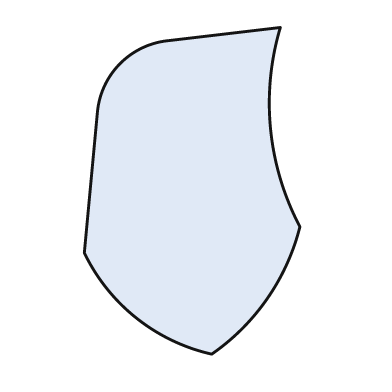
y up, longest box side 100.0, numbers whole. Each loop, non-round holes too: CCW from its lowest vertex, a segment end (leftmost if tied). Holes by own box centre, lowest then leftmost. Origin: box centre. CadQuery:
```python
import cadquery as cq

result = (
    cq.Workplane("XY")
    .moveTo(6.0, -50.0)
    .threePointArc((23.0, -33.0), (33.0, -11.0))
    .threePointArc((24.0, 19.0), (27.0, 50.0))
    .lineTo(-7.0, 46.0)
    .threePointArc((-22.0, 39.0), (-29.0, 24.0))
    .lineTo(-33.0, -19.0)
    .threePointArc((-17.0, -39.0), (6.0, -50.0))
    .close()
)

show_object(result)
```